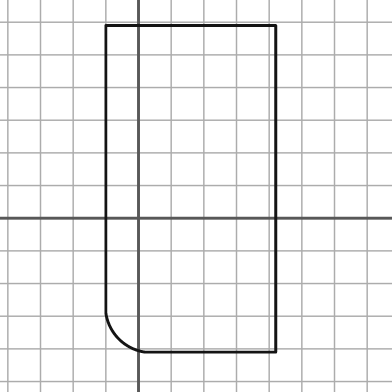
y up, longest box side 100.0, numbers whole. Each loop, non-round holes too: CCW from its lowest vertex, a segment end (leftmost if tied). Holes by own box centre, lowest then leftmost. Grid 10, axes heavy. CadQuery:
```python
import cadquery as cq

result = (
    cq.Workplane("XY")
    .moveTo(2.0, -41.0)
    .lineTo(42.0, -41.0)
    .lineTo(42.0, 59.0)
    .lineTo(-10.0, 59.0)
    .lineTo(-10.0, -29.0)
    .threePointArc((-6.0, -37.0), (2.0, -41.0))
    .close()
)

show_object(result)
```